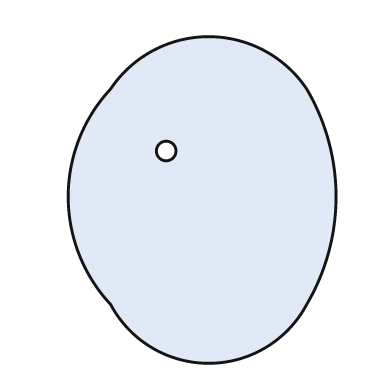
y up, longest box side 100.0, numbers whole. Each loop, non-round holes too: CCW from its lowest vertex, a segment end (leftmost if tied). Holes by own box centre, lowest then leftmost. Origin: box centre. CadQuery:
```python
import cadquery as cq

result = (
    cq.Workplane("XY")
    .moveTo(-28.0, -32.0)
    .threePointArc((2.0, -50.0), (32.0, -32.0))
    .threePointArc((41.0, 1.0), (32.0, 34.0))
    .threePointArc((2.0, 50.0), (-28.0, 34.0))
    .threePointArc((-41.0, 1.0), (-28.0, -32.0))
    .close()
    .moveTo(-11.0, 15.0)
    .circle(3.0)
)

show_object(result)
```